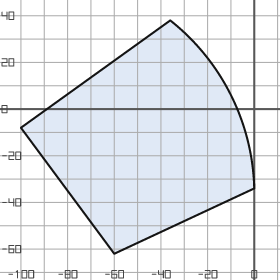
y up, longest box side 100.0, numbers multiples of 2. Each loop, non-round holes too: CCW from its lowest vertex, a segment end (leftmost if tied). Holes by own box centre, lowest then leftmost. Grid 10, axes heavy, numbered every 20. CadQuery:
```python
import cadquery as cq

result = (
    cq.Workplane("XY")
    .moveTo(-60.0, -62.0)
    .lineTo(0.0, -34.0)
    .threePointArc((-10.0, 6.0), (-36.0, 38.0))
    .lineTo(-100.0, -8.0)
    .close()
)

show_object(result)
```